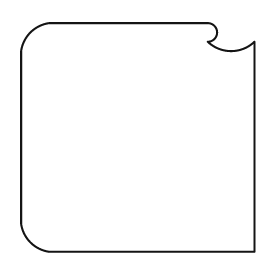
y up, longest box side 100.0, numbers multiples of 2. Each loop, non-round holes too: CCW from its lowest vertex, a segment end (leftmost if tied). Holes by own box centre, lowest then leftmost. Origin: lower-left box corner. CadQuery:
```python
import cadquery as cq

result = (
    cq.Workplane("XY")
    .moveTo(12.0, 0.0)
    .lineTo(100.0, 0.0)
    .lineTo(100.0, 90.0)
    .threePointArc((90.0, 86.0), (80.0, 90.0))
    .threePointArc((84.0, 94.0), (80.0, 98.0))
    .lineTo(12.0, 98.0)
    .threePointArc((4.0, 94.0), (0.0, 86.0))
    .lineTo(0.0, 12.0)
    .threePointArc((4.0, 4.0), (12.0, 0.0))
    .close()
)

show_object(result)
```